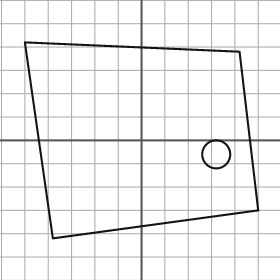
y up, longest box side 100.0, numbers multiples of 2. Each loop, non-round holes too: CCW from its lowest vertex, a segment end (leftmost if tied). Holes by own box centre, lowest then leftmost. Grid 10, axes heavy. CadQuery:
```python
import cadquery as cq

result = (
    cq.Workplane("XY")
    .moveTo(-38.0, -42.0)
    .lineTo(50.0, -30.0)
    .lineTo(42.0, 38.0)
    .lineTo(-50.0, 42.0)
    .close()
    .moveTo(32.0, -6.0)
    .circle(6.0)
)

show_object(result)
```